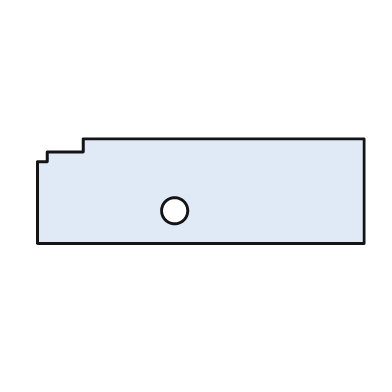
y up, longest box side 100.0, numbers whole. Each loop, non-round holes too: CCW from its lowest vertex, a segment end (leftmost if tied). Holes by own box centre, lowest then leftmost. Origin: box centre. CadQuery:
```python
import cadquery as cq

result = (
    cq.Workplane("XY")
    .moveTo(-50.0, -16.0)
    .lineTo(50.0, -16.0)
    .lineTo(50.0, 16.0)
    .lineTo(-36.0, 16.0)
    .lineTo(-36.0, 12.0)
    .lineTo(-47.0, 12.0)
    .lineTo(-47.0, 9.0)
    .lineTo(-50.0, 9.0)
    .close()
    .moveTo(-8.0, -6.0)
    .circle(4.0)
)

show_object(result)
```